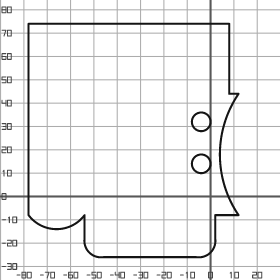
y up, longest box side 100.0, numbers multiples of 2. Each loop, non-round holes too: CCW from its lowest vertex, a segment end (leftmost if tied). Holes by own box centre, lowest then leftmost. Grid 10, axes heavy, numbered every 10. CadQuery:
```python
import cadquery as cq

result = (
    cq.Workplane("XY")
    .moveTo(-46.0, -26.0)
    .lineTo(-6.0, -26.0)
    .threePointArc((0.0, -24.0), (2.0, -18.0))
    .lineTo(2.0, -8.0)
    .lineTo(12.0, -8.0)
    .threePointArc((4.0, 18.0), (12.0, 44.0))
    .lineTo(8.0, 44.0)
    .lineTo(8.0, 74.0)
    .lineTo(-78.0, 74.0)
    .lineTo(-78.0, -8.0)
    .threePointArc((-66.0, -14.0), (-54.0, -8.0))
    .lineTo(-54.0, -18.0)
    .threePointArc((-52.0, -24.0), (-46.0, -26.0))
    .close()
    .moveTo(-4.0, 14.0)
    .circle(4.0)
    .moveTo(-4.0, 32.0)
    .circle(4.0)
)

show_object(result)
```